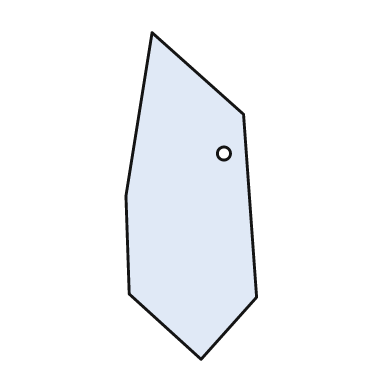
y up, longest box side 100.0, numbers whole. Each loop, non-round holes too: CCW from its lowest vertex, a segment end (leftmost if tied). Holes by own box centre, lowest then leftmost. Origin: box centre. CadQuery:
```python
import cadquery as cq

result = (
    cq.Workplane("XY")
    .moveTo(3.0, -50.0)
    .lineTo(20.0, -31.0)
    .lineTo(16.0, 25.0)
    .lineTo(-12.0, 50.0)
    .lineTo(-20.0, 0.0)
    .lineTo(-19.0, -30.0)
    .close()
    .moveTo(10.0, 13.0)
    .circle(2.0)
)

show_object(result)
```